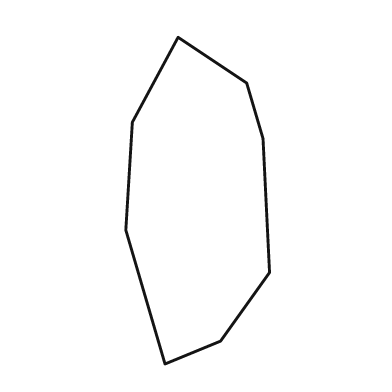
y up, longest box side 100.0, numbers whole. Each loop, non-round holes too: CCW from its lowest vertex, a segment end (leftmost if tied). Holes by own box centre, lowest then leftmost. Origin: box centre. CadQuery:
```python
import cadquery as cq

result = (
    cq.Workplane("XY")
    .moveTo(-10.0, -50.0)
    .lineTo(7.0, -43.0)
    .lineTo(22.0, -22.0)
    .lineTo(20.0, 19.0)
    .lineTo(15.0, 36.0)
    .lineTo(-6.0, 50.0)
    .lineTo(-20.0, 24.0)
    .lineTo(-22.0, -9.0)
    .close()
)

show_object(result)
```